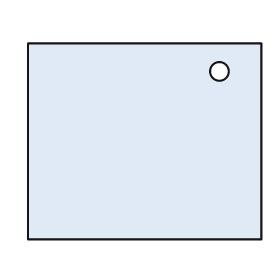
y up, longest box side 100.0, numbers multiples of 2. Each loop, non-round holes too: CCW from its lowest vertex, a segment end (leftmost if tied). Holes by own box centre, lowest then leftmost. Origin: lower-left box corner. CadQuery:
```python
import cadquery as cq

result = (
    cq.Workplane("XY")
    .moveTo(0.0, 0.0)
    .lineTo(100.0, 0.0)
    .lineTo(100.0, 84.0)
    .lineTo(0.0, 84.0)
    .close()
    .moveTo(82.0, 72.0)
    .circle(4.0)
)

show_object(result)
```